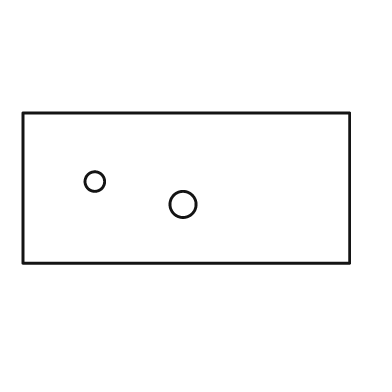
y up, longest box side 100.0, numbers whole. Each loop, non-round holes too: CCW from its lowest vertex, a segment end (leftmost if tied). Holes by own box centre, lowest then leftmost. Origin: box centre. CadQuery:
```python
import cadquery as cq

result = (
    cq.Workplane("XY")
    .moveTo(-50.0, -23.0)
    .lineTo(50.0, -23.0)
    .lineTo(50.0, 23.0)
    .lineTo(-50.0, 23.0)
    .close()
    .moveTo(-1.0, -5.0)
    .circle(4.0)
    .moveTo(-28.0, 2.0)
    .circle(3.0)
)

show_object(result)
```